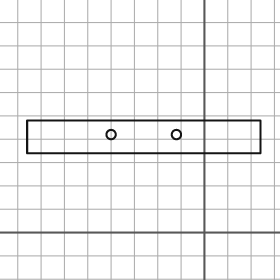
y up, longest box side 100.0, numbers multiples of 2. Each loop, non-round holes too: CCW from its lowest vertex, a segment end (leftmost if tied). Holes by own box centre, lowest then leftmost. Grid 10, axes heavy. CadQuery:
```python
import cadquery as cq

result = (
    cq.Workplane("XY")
    .moveTo(-76.0, 34.0)
    .lineTo(24.0, 34.0)
    .lineTo(24.0, 48.0)
    .lineTo(-76.0, 48.0)
    .close()
    .moveTo(-40.0, 42.0)
    .circle(2.0)
    .moveTo(-12.0, 42.0)
    .circle(2.0)
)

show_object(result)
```